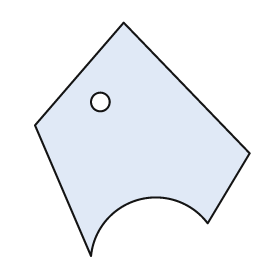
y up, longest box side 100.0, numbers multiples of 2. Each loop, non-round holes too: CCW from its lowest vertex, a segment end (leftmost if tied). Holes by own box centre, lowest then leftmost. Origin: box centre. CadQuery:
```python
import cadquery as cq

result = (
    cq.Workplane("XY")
    .moveTo(-22.0, -50.0)
    .threePointArc((-2.0, -26.0), (28.0, -36.0))
    .lineTo(46.0, -6.0)
    .lineTo(-8.0, 50.0)
    .lineTo(-46.0, 6.0)
    .close()
    .moveTo(-18.0, 16.0)
    .circle(4.0)
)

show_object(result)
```